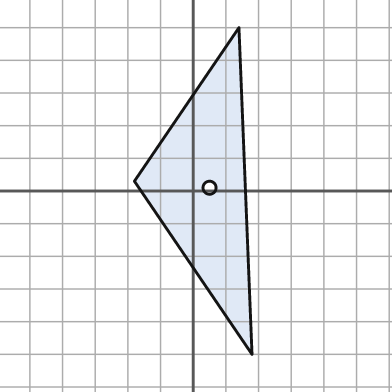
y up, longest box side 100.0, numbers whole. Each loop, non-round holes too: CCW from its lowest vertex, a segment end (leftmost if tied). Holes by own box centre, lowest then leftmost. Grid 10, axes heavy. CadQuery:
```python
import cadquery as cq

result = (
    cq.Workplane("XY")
    .moveTo(18.0, -50.0)
    .lineTo(14.0, 50.0)
    .lineTo(-18.0, 3.0)
    .close()
    .moveTo(5.0, 1.0)
    .circle(2.0)
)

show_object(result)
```